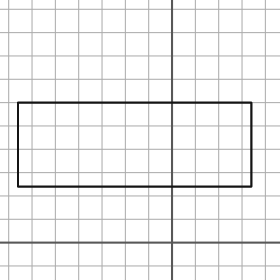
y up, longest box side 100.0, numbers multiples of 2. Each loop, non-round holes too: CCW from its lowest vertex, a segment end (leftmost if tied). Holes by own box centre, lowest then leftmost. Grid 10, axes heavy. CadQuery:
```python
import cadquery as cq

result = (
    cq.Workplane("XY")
    .moveTo(-66.0, 24.0)
    .lineTo(34.0, 24.0)
    .lineTo(34.0, 60.0)
    .lineTo(-66.0, 60.0)
    .close()
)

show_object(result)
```